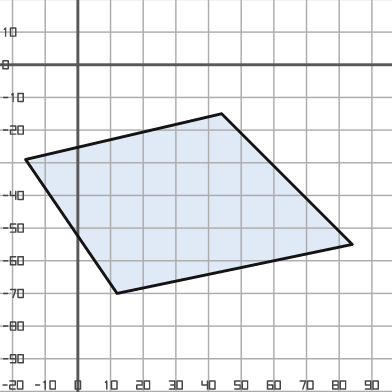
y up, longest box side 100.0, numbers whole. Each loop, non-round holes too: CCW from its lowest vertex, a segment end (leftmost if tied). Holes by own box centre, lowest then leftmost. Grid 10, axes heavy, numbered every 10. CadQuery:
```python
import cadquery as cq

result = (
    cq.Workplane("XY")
    .moveTo(12.0, -70.0)
    .lineTo(84.0, -55.0)
    .lineTo(44.0, -15.0)
    .lineTo(-16.0, -29.0)
    .close()
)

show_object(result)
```